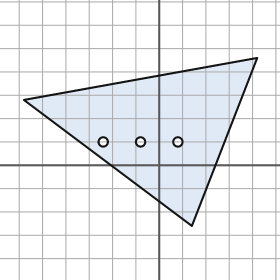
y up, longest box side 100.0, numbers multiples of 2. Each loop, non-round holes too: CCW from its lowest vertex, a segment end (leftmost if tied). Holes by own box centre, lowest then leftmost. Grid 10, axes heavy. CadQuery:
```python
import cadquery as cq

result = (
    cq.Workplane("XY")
    .moveTo(14.0, -26.0)
    .lineTo(42.0, 46.0)
    .lineTo(-58.0, 28.0)
    .close()
    .moveTo(-24.0, 10.0)
    .circle(2.0)
    .moveTo(-8.0, 10.0)
    .circle(2.0)
    .moveTo(8.0, 10.0)
    .circle(2.0)
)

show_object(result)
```